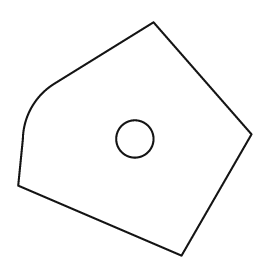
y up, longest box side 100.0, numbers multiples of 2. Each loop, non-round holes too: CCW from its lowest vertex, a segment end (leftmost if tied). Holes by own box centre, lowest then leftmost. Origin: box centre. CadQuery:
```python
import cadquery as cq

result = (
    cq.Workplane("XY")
    .moveTo(20.0, -50.0)
    .lineTo(50.0, 2.0)
    .lineTo(8.0, 50.0)
    .lineTo(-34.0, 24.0)
    .threePointArc((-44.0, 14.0), (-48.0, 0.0))
    .lineTo(-50.0, -20.0)
    .close()
    .moveTo(0.0, 0.0)
    .circle(8.0)
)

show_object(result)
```